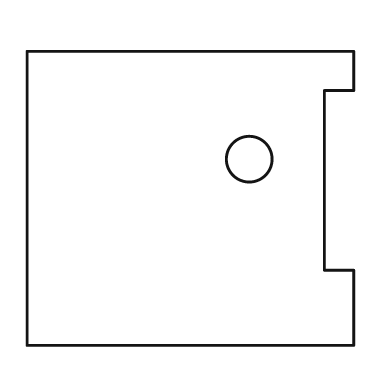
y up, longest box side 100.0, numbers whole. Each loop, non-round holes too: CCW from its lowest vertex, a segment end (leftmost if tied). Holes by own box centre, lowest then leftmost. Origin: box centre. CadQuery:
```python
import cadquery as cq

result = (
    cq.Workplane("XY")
    .moveTo(-50.0, -45.0)
    .lineTo(50.0, -45.0)
    .lineTo(50.0, -22.0)
    .lineTo(41.0, -22.0)
    .lineTo(41.0, 33.0)
    .lineTo(50.0, 33.0)
    .lineTo(50.0, 45.0)
    .lineTo(-50.0, 45.0)
    .close()
    .moveTo(18.0, 12.0)
    .circle(7.0)
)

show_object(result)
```